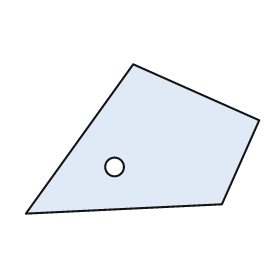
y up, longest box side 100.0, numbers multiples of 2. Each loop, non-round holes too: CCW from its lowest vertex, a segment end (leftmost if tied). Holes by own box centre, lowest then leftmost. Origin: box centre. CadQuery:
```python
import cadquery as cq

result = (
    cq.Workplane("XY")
    .moveTo(-50.0, -32.0)
    .lineTo(34.0, -28.0)
    .lineTo(50.0, 8.0)
    .lineTo(-4.0, 32.0)
    .close()
    .moveTo(-12.0, -12.0)
    .circle(4.0)
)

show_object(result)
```